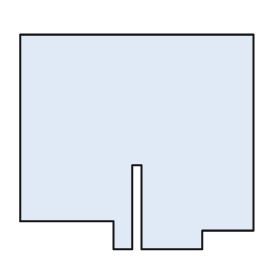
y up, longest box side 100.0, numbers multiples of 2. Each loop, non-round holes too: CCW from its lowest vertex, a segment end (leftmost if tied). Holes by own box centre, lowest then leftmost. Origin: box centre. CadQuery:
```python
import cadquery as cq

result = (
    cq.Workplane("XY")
    .moveTo(-10.0, -46.0)
    .lineTo(-2.0, -46.0)
    .lineTo(-2.0, -10.0)
    .lineTo(2.0, -10.0)
    .lineTo(2.0, -46.0)
    .lineTo(28.0, -46.0)
    .lineTo(28.0, -38.0)
    .lineTo(50.0, -38.0)
    .lineTo(50.0, 46.0)
    .lineTo(-50.0, 46.0)
    .lineTo(-50.0, -34.0)
    .lineTo(-10.0, -34.0)
    .close()
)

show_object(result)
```